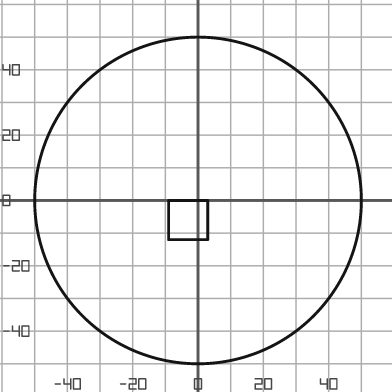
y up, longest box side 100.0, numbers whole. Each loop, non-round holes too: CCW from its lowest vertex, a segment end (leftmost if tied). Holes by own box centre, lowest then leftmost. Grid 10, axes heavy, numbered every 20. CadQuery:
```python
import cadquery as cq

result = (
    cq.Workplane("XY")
    .moveTo(0.0, 0.0)
    .circle(50.0)
    .moveTo(-9.0, -12.0)
    .lineTo(3.0, -12.0)
    .lineTo(3.0, 0.0)
    .lineTo(-9.0, 0.0)
    .close()
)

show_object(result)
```